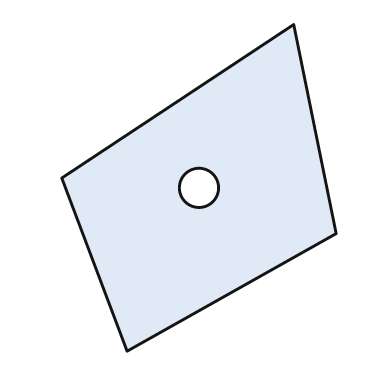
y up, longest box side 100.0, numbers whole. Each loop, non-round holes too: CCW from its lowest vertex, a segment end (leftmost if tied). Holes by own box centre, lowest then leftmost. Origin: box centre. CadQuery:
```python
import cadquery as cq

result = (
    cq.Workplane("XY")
    .moveTo(-22.0, -50.0)
    .lineTo(42.0, -14.0)
    .lineTo(29.0, 50.0)
    .lineTo(-42.0, 3.0)
    .close()
    .moveTo(0.0, 0.0)
    .circle(6.0)
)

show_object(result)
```